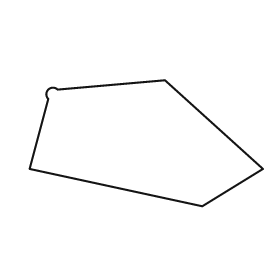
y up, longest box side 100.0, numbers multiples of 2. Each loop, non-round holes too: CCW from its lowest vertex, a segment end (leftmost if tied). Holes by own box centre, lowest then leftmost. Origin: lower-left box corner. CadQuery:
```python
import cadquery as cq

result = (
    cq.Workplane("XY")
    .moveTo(74.0, 0.0)
    .lineTo(100.0, 16.0)
    .lineTo(58.0, 54.0)
    .lineTo(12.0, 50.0)
    .threePointArc((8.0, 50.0), (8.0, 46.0))
    .lineTo(0.0, 16.0)
    .close()
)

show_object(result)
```